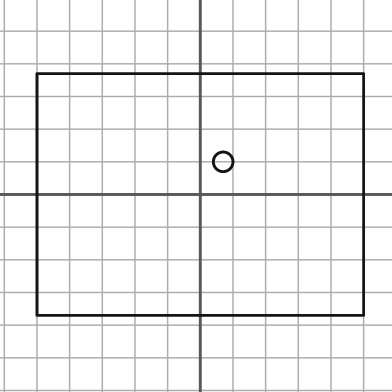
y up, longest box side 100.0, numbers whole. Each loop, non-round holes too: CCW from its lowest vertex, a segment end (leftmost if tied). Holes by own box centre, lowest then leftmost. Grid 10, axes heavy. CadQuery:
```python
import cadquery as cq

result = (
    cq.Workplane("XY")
    .moveTo(-50.0, -37.0)
    .lineTo(50.0, -37.0)
    .lineTo(50.0, 37.0)
    .lineTo(-50.0, 37.0)
    .close()
    .moveTo(7.0, 10.0)
    .circle(3.0)
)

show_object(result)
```